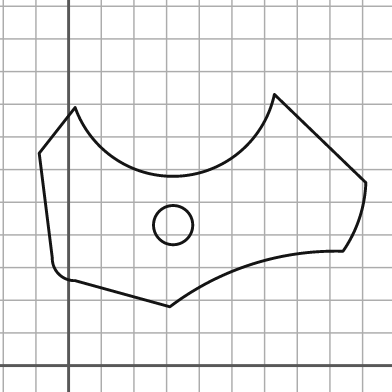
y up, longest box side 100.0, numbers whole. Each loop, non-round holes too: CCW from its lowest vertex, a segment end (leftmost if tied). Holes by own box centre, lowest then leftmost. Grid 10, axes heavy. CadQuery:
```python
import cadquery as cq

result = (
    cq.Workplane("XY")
    .moveTo(31.0, 18.0)
    .threePointArc((56.0, 31.0), (84.0, 35.0))
    .threePointArc((89.0, 45.0), (91.0, 56.0))
    .lineTo(63.0, 83.0)
    .threePointArc((34.0, 58.0), (2.0, 79.0))
    .lineTo(-9.0, 65.0)
    .lineTo(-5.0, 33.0)
    .threePointArc((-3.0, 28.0), (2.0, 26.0))
    .close()
    .moveTo(32.0, 43.0)
    .circle(6.0)
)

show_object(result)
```